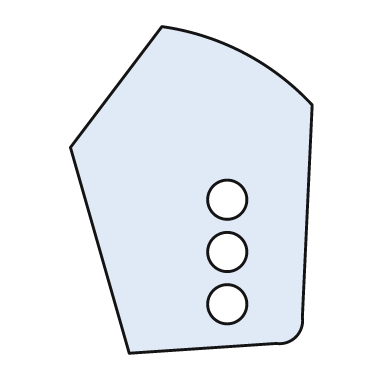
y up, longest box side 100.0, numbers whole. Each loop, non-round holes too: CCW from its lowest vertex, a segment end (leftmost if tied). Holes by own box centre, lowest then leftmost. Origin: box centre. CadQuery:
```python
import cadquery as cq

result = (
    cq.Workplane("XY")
    .moveTo(-19.0, -50.0)
    .lineTo(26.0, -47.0)
    .threePointArc((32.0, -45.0), (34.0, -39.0))
    .lineTo(37.0, 26.0)
    .threePointArc((16.0, 42.0), (-9.0, 50.0))
    .lineTo(-37.0, 13.0)
    .close()
    .moveTo(11.0, -35.0)
    .circle(6.0)
    .moveTo(11.0, -19.0)
    .circle(6.0)
    .moveTo(11.0, -3.0)
    .circle(6.0)
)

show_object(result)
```